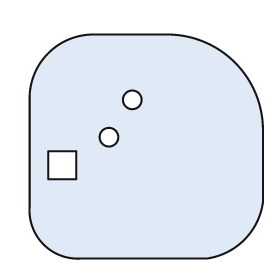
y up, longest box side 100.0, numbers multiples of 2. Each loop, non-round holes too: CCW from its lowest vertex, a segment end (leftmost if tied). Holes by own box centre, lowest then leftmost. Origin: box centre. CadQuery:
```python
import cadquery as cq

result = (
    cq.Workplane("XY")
    .moveTo(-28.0, -48.0)
    .lineTo(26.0, -48.0)
    .threePointArc((42.0, -40.0), (50.0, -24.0))
    .lineTo(50.0, 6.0)
    .threePointArc((38.0, 36.0), (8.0, 48.0))
    .lineTo(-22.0, 48.0)
    .threePointArc((-42.0, 40.0), (-50.0, 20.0))
    .lineTo(-50.0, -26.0)
    .threePointArc((-44.0, -42.0), (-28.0, -48.0))
    .close()
    .moveTo(-42.0, -14.0)
    .lineTo(-30.0, -14.0)
    .lineTo(-30.0, -2.0)
    .lineTo(-42.0, -2.0)
    .close()
    .moveTo(-16.0, 4.0)
    .circle(4.0)
    .moveTo(-6.0, 20.0)
    .circle(4.0)
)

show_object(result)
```